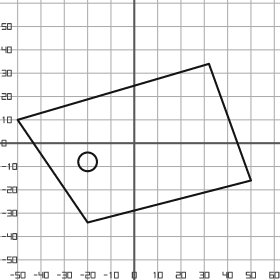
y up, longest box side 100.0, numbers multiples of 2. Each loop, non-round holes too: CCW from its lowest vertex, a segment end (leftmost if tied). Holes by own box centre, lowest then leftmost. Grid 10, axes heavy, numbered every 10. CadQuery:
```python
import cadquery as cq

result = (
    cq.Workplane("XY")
    .moveTo(-20.0, -34.0)
    .lineTo(50.0, -16.0)
    .lineTo(32.0, 34.0)
    .lineTo(-50.0, 10.0)
    .close()
    .moveTo(-20.0, -8.0)
    .circle(4.0)
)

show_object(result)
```